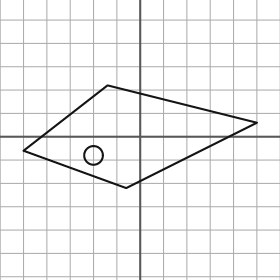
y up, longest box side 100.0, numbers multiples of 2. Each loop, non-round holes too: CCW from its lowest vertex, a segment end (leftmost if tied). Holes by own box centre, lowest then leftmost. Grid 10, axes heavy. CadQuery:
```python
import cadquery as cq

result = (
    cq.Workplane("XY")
    .moveTo(-6.0, -22.0)
    .lineTo(50.0, 6.0)
    .lineTo(-14.0, 22.0)
    .lineTo(-50.0, -6.0)
    .close()
    .moveTo(-20.0, -8.0)
    .circle(4.0)
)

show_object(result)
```